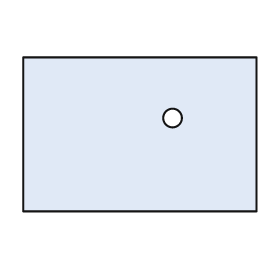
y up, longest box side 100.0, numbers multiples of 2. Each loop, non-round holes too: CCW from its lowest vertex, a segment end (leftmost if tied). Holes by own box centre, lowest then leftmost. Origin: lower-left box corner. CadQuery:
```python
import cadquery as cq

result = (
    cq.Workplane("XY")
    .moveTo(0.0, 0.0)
    .lineTo(100.0, 0.0)
    .lineTo(100.0, 66.0)
    .lineTo(0.0, 66.0)
    .close()
    .moveTo(64.0, 40.0)
    .circle(4.0)
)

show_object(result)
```